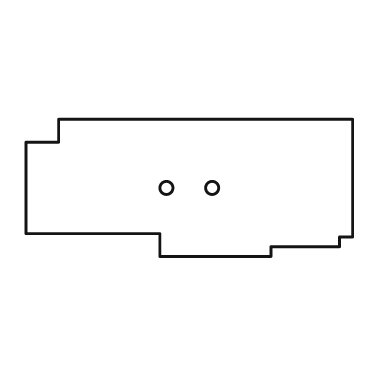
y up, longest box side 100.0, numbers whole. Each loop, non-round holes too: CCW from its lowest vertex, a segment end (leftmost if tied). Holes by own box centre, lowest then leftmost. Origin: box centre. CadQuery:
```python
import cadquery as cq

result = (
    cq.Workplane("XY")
    .moveTo(-9.0, -21.0)
    .lineTo(25.0, -21.0)
    .lineTo(25.0, -18.0)
    .lineTo(46.0, -18.0)
    .lineTo(46.0, -15.0)
    .lineTo(50.0, -15.0)
    .lineTo(50.0, 21.0)
    .lineTo(-40.0, 21.0)
    .lineTo(-40.0, 14.0)
    .lineTo(-50.0, 14.0)
    .lineTo(-50.0, -14.0)
    .lineTo(-9.0, -14.0)
    .close()
    .moveTo(-7.0, 0.0)
    .circle(2.0)
    .moveTo(7.0, 0.0)
    .circle(2.0)
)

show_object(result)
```